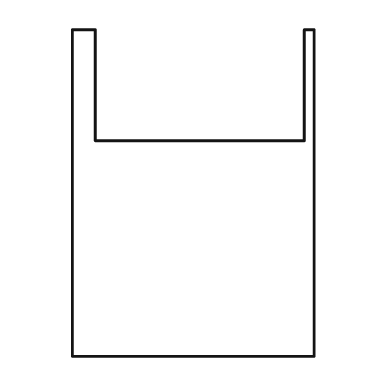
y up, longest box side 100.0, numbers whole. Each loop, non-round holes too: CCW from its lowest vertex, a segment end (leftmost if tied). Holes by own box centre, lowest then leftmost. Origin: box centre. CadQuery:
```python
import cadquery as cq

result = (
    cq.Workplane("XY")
    .moveTo(-37.0, -50.0)
    .lineTo(37.0, -50.0)
    .lineTo(37.0, 50.0)
    .lineTo(34.0, 50.0)
    .lineTo(34.0, 16.0)
    .lineTo(-30.0, 16.0)
    .lineTo(-30.0, 50.0)
    .lineTo(-37.0, 50.0)
    .close()
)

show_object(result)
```